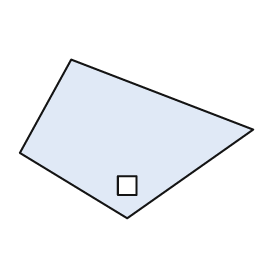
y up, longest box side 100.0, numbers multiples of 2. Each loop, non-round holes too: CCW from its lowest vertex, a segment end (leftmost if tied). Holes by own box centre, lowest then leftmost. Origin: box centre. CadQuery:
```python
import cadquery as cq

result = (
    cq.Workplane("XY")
    .moveTo(-4.0, -34.0)
    .lineTo(50.0, 4.0)
    .lineTo(-28.0, 34.0)
    .lineTo(-50.0, -6.0)
    .close()
    .moveTo(-8.0, -24.0)
    .lineTo(0.0, -24.0)
    .lineTo(0.0, -16.0)
    .lineTo(-8.0, -16.0)
    .close()
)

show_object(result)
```